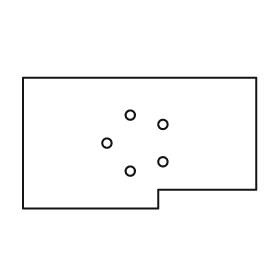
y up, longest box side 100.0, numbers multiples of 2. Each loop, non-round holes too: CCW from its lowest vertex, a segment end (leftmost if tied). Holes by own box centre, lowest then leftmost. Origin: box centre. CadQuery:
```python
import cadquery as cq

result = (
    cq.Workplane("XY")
    .moveTo(-50.0, -28.0)
    .lineTo(8.0, -28.0)
    .lineTo(8.0, -20.0)
    .lineTo(50.0, -20.0)
    .lineTo(50.0, 28.0)
    .lineTo(-50.0, 28.0)
    .close()
    .moveTo(-4.0, -12.0)
    .circle(2.0)
    .moveTo(10.0, -8.0)
    .circle(2.0)
    .moveTo(-14.0, 0.0)
    .circle(2.0)
    .moveTo(10.0, 8.0)
    .circle(2.0)
    .moveTo(-4.0, 12.0)
    .circle(2.0)
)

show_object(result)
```